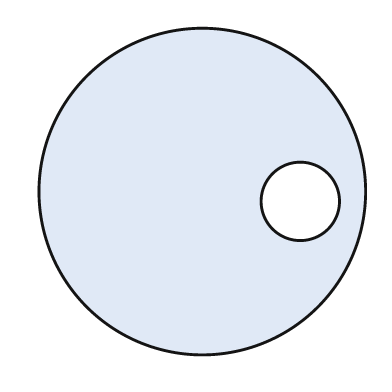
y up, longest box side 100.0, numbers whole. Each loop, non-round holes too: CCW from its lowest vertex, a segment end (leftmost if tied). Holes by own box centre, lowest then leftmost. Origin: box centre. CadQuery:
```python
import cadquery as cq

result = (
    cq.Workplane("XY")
    .moveTo(0.0, 0.0)
    .circle(50.0)
    .moveTo(30.0, -3.0)
    .circle(12.0)
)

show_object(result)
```